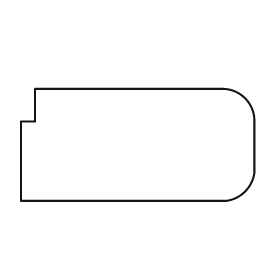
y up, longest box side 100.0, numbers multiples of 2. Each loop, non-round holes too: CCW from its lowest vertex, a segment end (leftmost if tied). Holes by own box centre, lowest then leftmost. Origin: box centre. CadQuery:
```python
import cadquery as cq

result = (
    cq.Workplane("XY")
    .moveTo(-50.0, -24.0)
    .lineTo(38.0, -24.0)
    .threePointArc((46.0, -20.0), (50.0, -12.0))
    .lineTo(50.0, 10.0)
    .threePointArc((46.0, 20.0), (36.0, 24.0))
    .lineTo(-44.0, 24.0)
    .lineTo(-44.0, 10.0)
    .lineTo(-50.0, 10.0)
    .close()
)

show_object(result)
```